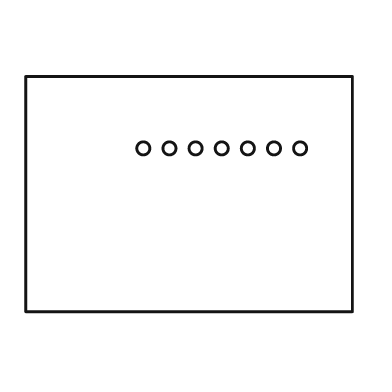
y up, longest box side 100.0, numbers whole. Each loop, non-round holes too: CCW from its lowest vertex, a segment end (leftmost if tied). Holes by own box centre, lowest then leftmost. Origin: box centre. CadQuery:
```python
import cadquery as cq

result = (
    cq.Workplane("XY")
    .moveTo(-50.0, -36.0)
    .lineTo(50.0, -36.0)
    .lineTo(50.0, 36.0)
    .lineTo(-50.0, 36.0)
    .close()
    .moveTo(-14.0, 14.0)
    .circle(2.0)
    .moveTo(-6.0, 14.0)
    .circle(2.0)
    .moveTo(2.0, 14.0)
    .circle(2.0)
    .moveTo(10.0, 14.0)
    .circle(2.0)
    .moveTo(18.0, 14.0)
    .circle(2.0)
    .moveTo(26.0, 14.0)
    .circle(2.0)
    .moveTo(34.0, 14.0)
    .circle(2.0)
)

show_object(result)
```